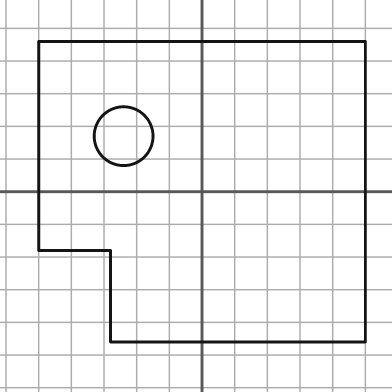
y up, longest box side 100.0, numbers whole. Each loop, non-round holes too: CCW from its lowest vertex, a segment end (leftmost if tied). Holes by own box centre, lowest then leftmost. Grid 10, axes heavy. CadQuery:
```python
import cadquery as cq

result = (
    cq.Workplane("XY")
    .moveTo(-28.0, -46.0)
    .lineTo(50.0, -46.0)
    .lineTo(50.0, 46.0)
    .lineTo(-50.0, 46.0)
    .lineTo(-50.0, -18.0)
    .lineTo(-28.0, -18.0)
    .close()
    .moveTo(-24.0, 17.0)
    .circle(9.0)
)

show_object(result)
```